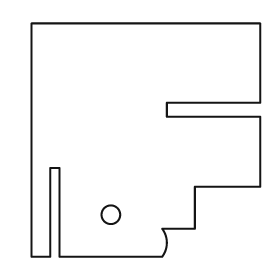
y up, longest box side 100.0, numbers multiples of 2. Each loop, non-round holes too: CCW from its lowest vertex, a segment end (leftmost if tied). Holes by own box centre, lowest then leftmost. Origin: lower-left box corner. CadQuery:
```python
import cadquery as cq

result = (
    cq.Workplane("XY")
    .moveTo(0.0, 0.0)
    .lineTo(8.0, 0.0)
    .lineTo(8.0, 38.0)
    .lineTo(12.0, 38.0)
    .lineTo(12.0, 0.0)
    .lineTo(56.0, 0.0)
    .threePointArc((58.0, 6.0), (56.0, 12.0))
    .lineTo(70.0, 12.0)
    .lineTo(70.0, 30.0)
    .lineTo(98.0, 30.0)
    .lineTo(98.0, 60.0)
    .lineTo(58.0, 60.0)
    .lineTo(58.0, 66.0)
    .lineTo(98.0, 66.0)
    .lineTo(98.0, 100.0)
    .lineTo(0.0, 100.0)
    .close()
    .moveTo(34.0, 18.0)
    .circle(4.0)
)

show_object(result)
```